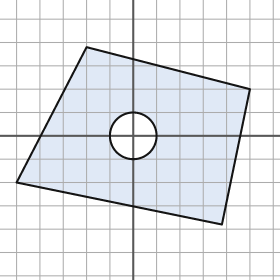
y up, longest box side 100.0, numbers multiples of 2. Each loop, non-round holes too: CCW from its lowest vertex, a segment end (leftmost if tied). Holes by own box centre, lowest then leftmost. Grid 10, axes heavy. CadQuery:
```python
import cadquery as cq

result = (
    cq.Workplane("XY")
    .moveTo(38.0, -38.0)
    .lineTo(50.0, 20.0)
    .lineTo(-20.0, 38.0)
    .lineTo(-50.0, -20.0)
    .close()
    .moveTo(0.0, 0.0)
    .circle(10.0)
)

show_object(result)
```